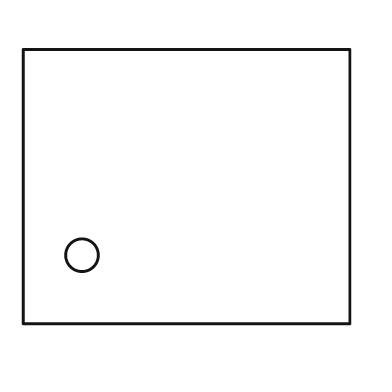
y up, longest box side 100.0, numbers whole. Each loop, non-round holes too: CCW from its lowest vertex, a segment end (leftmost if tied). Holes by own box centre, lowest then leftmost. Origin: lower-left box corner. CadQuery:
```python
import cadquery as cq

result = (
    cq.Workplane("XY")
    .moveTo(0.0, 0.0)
    .lineTo(100.0, 0.0)
    .lineTo(100.0, 84.0)
    .lineTo(0.0, 84.0)
    .close()
    .moveTo(18.0, 21.0)
    .circle(5.0)
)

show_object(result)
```